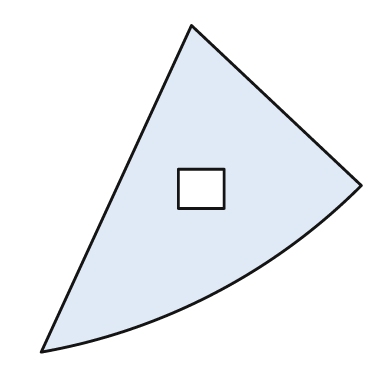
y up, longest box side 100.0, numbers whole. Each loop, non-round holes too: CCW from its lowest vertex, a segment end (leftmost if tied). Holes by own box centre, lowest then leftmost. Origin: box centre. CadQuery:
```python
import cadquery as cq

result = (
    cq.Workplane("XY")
    .moveTo(-49.0, -50.0)
    .threePointArc((4.0, -32.0), (49.0, 1.0))
    .lineTo(-3.0, 50.0)
    .close()
    .moveTo(-7.0, -6.0)
    .lineTo(7.0, -6.0)
    .lineTo(7.0, 6.0)
    .lineTo(-7.0, 6.0)
    .close()
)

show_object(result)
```